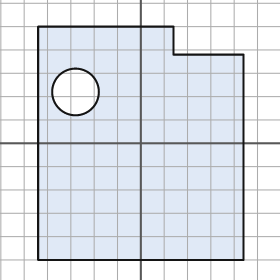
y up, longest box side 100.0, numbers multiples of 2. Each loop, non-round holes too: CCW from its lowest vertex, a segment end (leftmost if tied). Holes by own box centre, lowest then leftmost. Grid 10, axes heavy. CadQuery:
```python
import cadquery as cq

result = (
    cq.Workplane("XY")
    .moveTo(-44.0, -50.0)
    .lineTo(44.0, -50.0)
    .lineTo(44.0, 38.0)
    .lineTo(14.0, 38.0)
    .lineTo(14.0, 50.0)
    .lineTo(-44.0, 50.0)
    .close()
    .moveTo(-28.0, 22.0)
    .circle(10.0)
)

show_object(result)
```